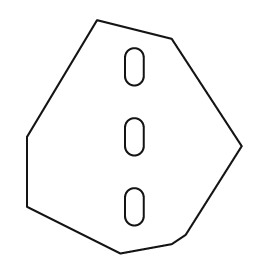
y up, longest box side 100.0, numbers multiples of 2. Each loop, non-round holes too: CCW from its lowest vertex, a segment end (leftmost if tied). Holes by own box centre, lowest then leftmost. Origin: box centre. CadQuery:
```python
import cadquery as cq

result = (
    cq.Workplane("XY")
    .moveTo(-6.0, -50.0)
    .lineTo(16.0, -46.0)
    .lineTo(22.0, -42.0)
    .lineTo(46.0, -4.0)
    .lineTo(16.0, 42.0)
    .lineTo(-16.0, 50.0)
    .lineTo(-46.0, 0.0)
    .lineTo(-46.0, -30.0)
    .close()
    .moveTo(-4.0, -34.0)
    .threePointArc((0.0, -38.0), (4.0, -34.0))
    .lineTo(4.0, -26.0)
    .threePointArc((0.0, -22.0), (-4.0, -26.0))
    .close()
    .moveTo(-4.0, -4.0)
    .threePointArc((0.0, -8.0), (4.0, -4.0))
    .lineTo(4.0, 4.0)
    .threePointArc((0.0, 8.0), (-4.0, 4.0))
    .close()
    .moveTo(-4.0, 26.0)
    .threePointArc((0.0, 22.0), (4.0, 26.0))
    .lineTo(4.0, 34.0)
    .threePointArc((0.0, 38.0), (-4.0, 34.0))
    .close()
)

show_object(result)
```